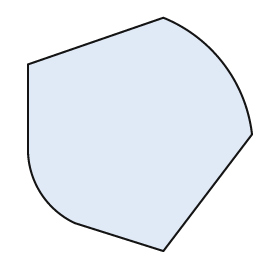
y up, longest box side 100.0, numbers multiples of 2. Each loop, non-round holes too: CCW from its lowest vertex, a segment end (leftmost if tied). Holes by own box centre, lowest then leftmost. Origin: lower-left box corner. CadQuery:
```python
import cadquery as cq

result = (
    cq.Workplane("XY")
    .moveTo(58.0, 0.0)
    .lineTo(96.0, 50.0)
    .threePointArc((84.0, 80.0), (58.0, 100.0))
    .lineTo(0.0, 80.0)
    .lineTo(0.0, 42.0)
    .threePointArc((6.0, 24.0), (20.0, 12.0))
    .close()
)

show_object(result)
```